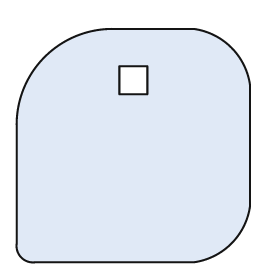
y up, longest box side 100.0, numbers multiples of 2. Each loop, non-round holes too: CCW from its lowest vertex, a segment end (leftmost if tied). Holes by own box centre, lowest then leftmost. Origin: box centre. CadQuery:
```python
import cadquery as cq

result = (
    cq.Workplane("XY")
    .moveTo(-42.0, -50.0)
    .lineTo(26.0, -50.0)
    .threePointArc((42.0, -42.0), (50.0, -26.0))
    .lineTo(50.0, 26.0)
    .threePointArc((42.0, 42.0), (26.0, 50.0))
    .lineTo(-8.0, 50.0)
    .threePointArc((-38.0, 38.0), (-50.0, 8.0))
    .lineTo(-50.0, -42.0)
    .threePointArc((-48.0, -48.0), (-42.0, -50.0))
    .close()
    .moveTo(-6.0, 22.0)
    .lineTo(6.0, 22.0)
    .lineTo(6.0, 34.0)
    .lineTo(-6.0, 34.0)
    .close()
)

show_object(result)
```